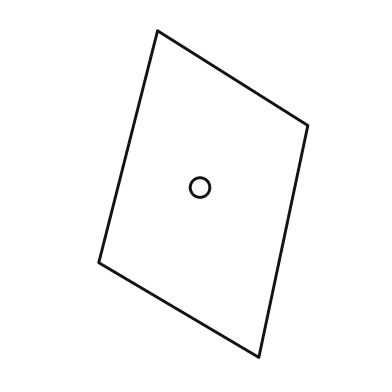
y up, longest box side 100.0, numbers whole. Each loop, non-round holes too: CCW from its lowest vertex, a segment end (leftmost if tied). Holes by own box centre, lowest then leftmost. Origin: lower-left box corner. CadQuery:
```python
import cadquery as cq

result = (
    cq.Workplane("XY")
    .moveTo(49.0, 0.0)
    .lineTo(64.0, 71.0)
    .lineTo(18.0, 100.0)
    .lineTo(0.0, 29.0)
    .close()
    .moveTo(31.0, 52.0)
    .circle(3.0)
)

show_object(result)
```